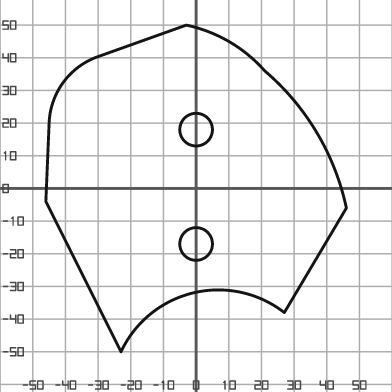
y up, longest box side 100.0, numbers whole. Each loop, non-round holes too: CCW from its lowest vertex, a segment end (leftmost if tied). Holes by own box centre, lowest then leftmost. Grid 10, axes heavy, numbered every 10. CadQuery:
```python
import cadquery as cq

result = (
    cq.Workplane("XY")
    .moveTo(-23.0, -50.0)
    .threePointArc((-1.0, -32.0), (27.0, -38.0))
    .lineTo(46.0, -6.0)
    .threePointArc((37.0, 17.0), (21.0, 36.0))
    .threePointArc((10.0, 45.0), (-3.0, 50.0))
    .lineTo(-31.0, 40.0)
    .threePointArc((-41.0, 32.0), (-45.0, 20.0))
    .lineTo(-46.0, -4.0)
    .close()
    .moveTo(0.0, -17.0)
    .circle(5.0)
    .moveTo(0.0, 18.0)
    .circle(5.0)
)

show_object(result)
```